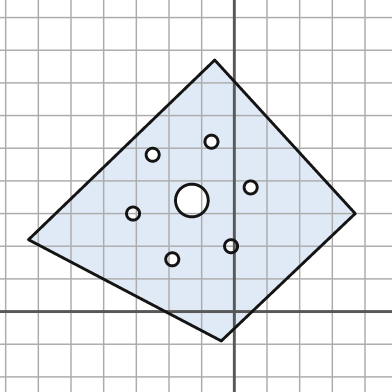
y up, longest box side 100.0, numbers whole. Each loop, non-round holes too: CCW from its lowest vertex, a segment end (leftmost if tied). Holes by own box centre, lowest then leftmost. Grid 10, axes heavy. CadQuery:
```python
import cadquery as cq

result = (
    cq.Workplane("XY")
    .moveTo(-4.0, -9.0)
    .lineTo(37.0, 30.0)
    .lineTo(-6.0, 77.0)
    .lineTo(-63.0, 22.0)
    .close()
    .moveTo(-19.0, 16.0)
    .circle(2.0)
    .moveTo(-1.0, 20.0)
    .circle(2.0)
    .moveTo(-31.0, 30.0)
    .circle(2.0)
    .moveTo(-13.0, 34.0)
    .circle(5.0)
    .moveTo(5.0, 38.0)
    .circle(2.0)
    .moveTo(-25.0, 48.0)
    .circle(2.0)
    .moveTo(-7.0, 52.0)
    .circle(2.0)
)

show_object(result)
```